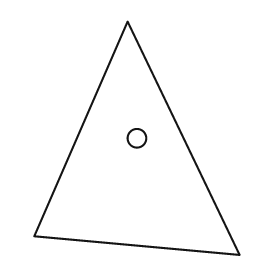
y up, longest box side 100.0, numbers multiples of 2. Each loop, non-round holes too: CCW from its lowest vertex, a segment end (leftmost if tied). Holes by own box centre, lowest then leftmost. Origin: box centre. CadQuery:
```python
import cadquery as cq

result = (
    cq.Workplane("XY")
    .moveTo(44.0, -50.0)
    .lineTo(-4.0, 50.0)
    .lineTo(-44.0, -42.0)
    .close()
    .moveTo(0.0, 0.0)
    .circle(4.0)
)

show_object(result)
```